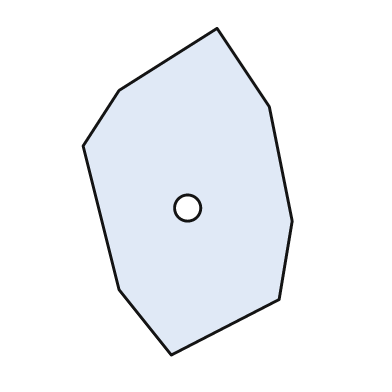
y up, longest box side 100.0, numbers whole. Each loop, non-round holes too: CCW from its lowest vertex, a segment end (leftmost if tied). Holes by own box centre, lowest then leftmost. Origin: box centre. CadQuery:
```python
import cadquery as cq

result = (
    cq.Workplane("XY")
    .moveTo(-5.0, -50.0)
    .lineTo(28.0, -33.0)
    .lineTo(32.0, -9.0)
    .lineTo(25.0, 26.0)
    .lineTo(9.0, 50.0)
    .lineTo(-21.0, 31.0)
    .lineTo(-32.0, 14.0)
    .lineTo(-21.0, -30.0)
    .close()
    .moveTo(0.0, -5.0)
    .circle(4.0)
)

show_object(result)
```